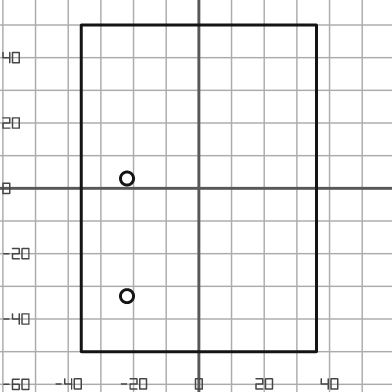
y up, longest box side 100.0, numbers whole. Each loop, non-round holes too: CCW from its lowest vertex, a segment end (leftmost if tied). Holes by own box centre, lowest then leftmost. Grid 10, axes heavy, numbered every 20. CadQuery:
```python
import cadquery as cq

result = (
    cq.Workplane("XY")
    .moveTo(-36.0, -50.0)
    .lineTo(36.0, -50.0)
    .lineTo(36.0, 50.0)
    .lineTo(-36.0, 50.0)
    .close()
    .moveTo(-22.0, -33.0)
    .circle(2.0)
    .moveTo(-22.0, 3.0)
    .circle(2.0)
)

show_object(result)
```